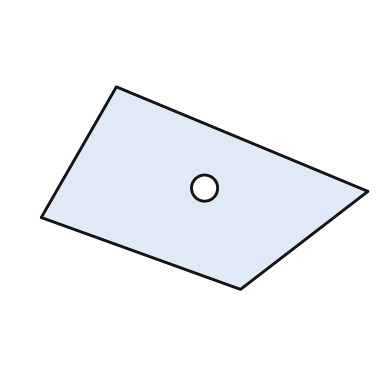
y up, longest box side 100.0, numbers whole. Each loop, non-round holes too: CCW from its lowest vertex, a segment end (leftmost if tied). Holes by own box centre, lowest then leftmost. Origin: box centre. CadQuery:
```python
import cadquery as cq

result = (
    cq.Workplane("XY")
    .moveTo(11.0, -31.0)
    .lineTo(50.0, -1.0)
    .lineTo(-27.0, 31.0)
    .lineTo(-50.0, -9.0)
    .close()
    .moveTo(0.0, 0.0)
    .circle(4.0)
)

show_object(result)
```